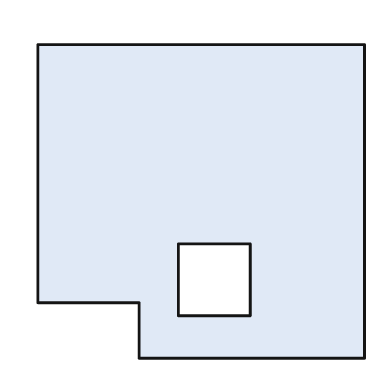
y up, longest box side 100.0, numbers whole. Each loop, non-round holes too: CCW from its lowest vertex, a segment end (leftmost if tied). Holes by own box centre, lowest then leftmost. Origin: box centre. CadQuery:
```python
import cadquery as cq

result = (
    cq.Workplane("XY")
    .moveTo(-19.0, -48.0)
    .lineTo(50.0, -48.0)
    .lineTo(50.0, 48.0)
    .lineTo(-50.0, 48.0)
    .lineTo(-50.0, -31.0)
    .lineTo(-19.0, -31.0)
    .close()
    .moveTo(-7.0, -35.0)
    .lineTo(15.0, -35.0)
    .lineTo(15.0, -13.0)
    .lineTo(-7.0, -13.0)
    .close()
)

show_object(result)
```